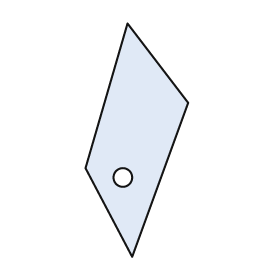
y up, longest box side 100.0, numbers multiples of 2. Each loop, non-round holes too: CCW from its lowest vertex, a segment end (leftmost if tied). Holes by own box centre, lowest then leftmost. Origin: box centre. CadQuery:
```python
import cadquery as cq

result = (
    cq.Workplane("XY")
    .moveTo(-2.0, -50.0)
    .lineTo(22.0, 16.0)
    .lineTo(-4.0, 50.0)
    .lineTo(-22.0, -12.0)
    .close()
    .moveTo(-6.0, -16.0)
    .circle(4.0)
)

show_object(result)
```